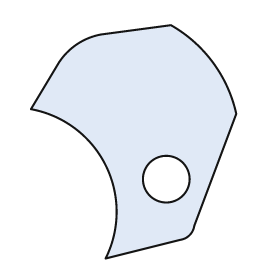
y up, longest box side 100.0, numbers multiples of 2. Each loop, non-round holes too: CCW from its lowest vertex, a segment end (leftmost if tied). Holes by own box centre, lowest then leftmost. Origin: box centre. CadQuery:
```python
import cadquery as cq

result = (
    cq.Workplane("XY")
    .moveTo(-12.0, -50.0)
    .lineTo(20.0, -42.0)
    .threePointArc((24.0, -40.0), (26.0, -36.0))
    .lineTo(44.0, 12.0)
    .threePointArc((34.0, 34.0), (16.0, 50.0))
    .lineTo(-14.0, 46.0)
    .threePointArc((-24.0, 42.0), (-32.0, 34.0))
    .lineTo(-44.0, 14.0)
    .threePointArc((-12.0, -10.0), (-12.0, -50.0))
    .close()
    .moveTo(14.0, -16.0)
    .circle(10.0)
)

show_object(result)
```